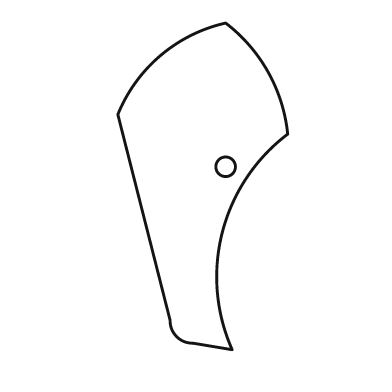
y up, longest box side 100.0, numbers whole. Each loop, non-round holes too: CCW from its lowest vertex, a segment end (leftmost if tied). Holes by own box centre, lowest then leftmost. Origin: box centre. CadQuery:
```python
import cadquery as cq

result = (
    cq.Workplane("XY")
    .moveTo(9.0, -50.0)
    .threePointArc((6.0, -14.0), (26.0, 16.0))
    .threePointArc((20.0, 35.0), (7.0, 50.0))
    .threePointArc((-13.0, 40.0), (-26.0, 22.0))
    .lineTo(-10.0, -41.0)
    .threePointArc((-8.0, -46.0), (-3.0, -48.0))
    .close()
    .moveTo(7.0, 6.0)
    .circle(3.0)
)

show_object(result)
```